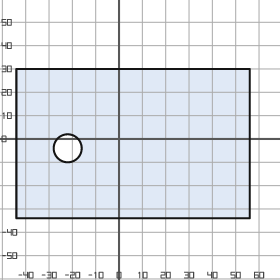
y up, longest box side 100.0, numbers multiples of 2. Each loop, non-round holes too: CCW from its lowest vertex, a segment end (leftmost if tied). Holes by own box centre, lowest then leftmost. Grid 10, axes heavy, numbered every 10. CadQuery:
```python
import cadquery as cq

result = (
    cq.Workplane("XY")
    .moveTo(-44.0, -34.0)
    .lineTo(56.0, -34.0)
    .lineTo(56.0, 30.0)
    .lineTo(-44.0, 30.0)
    .close()
    .moveTo(-22.0, -4.0)
    .circle(6.0)
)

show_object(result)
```